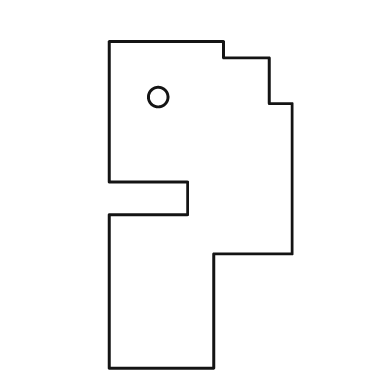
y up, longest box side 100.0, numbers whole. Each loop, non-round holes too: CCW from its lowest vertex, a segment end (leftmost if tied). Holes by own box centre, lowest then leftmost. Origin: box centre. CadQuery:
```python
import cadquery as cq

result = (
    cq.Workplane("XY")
    .moveTo(-28.0, -50.0)
    .lineTo(4.0, -50.0)
    .lineTo(4.0, -15.0)
    .lineTo(28.0, -15.0)
    .lineTo(28.0, 31.0)
    .lineTo(21.0, 31.0)
    .lineTo(21.0, 45.0)
    .lineTo(7.0, 45.0)
    .lineTo(7.0, 50.0)
    .lineTo(-28.0, 50.0)
    .lineTo(-28.0, 7.0)
    .lineTo(-4.0, 7.0)
    .lineTo(-4.0, -3.0)
    .lineTo(-28.0, -3.0)
    .close()
    .moveTo(-13.0, 33.0)
    .circle(3.0)
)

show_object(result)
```